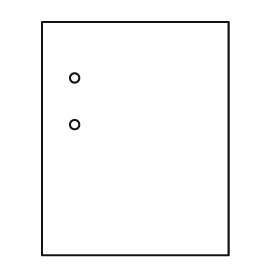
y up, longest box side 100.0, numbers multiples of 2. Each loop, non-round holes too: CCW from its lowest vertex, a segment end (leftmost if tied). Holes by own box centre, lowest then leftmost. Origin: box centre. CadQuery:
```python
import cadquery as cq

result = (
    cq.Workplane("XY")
    .moveTo(-40.0, -50.0)
    .lineTo(40.0, -50.0)
    .lineTo(40.0, 50.0)
    .lineTo(-40.0, 50.0)
    .close()
    .moveTo(-26.0, 6.0)
    .circle(2.0)
    .moveTo(-26.0, 26.0)
    .circle(2.0)
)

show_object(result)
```